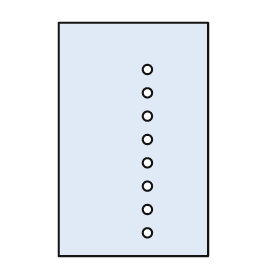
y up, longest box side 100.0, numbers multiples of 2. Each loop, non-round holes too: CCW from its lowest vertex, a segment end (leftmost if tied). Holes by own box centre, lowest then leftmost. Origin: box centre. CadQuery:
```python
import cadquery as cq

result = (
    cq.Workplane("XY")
    .moveTo(-32.0, -50.0)
    .lineTo(32.0, -50.0)
    .lineTo(32.0, 50.0)
    .lineTo(-32.0, 50.0)
    .close()
    .moveTo(6.0, -40.0)
    .circle(2.0)
    .moveTo(6.0, -30.0)
    .circle(2.0)
    .moveTo(6.0, -20.0)
    .circle(2.0)
    .moveTo(6.0, -10.0)
    .circle(2.0)
    .moveTo(6.0, 0.0)
    .circle(2.0)
    .moveTo(6.0, 10.0)
    .circle(2.0)
    .moveTo(6.0, 20.0)
    .circle(2.0)
    .moveTo(6.0, 30.0)
    .circle(2.0)
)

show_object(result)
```